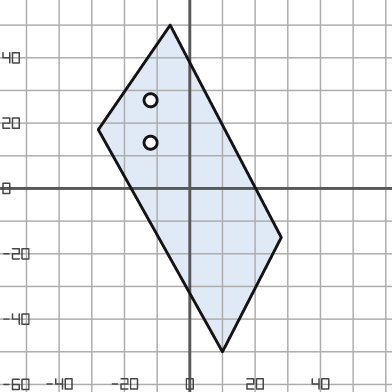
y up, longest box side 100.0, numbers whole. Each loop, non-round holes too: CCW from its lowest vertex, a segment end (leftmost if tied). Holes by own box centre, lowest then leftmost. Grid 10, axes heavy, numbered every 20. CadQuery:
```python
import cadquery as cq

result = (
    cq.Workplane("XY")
    .moveTo(10.0, -50.0)
    .lineTo(28.0, -15.0)
    .lineTo(-6.0, 50.0)
    .lineTo(-28.0, 18.0)
    .close()
    .moveTo(-12.0, 14.0)
    .circle(2.0)
    .moveTo(-12.0, 27.0)
    .circle(2.0)
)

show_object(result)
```